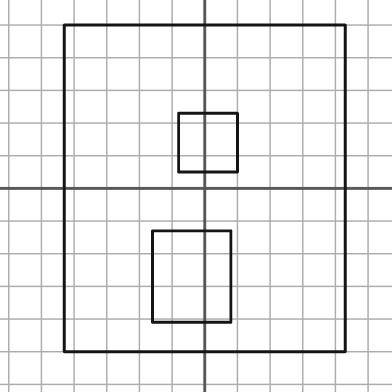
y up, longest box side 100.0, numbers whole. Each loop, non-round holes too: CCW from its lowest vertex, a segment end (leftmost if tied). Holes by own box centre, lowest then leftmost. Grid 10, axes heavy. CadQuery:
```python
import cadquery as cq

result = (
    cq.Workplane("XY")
    .moveTo(-43.0, -50.0)
    .lineTo(43.0, -50.0)
    .lineTo(43.0, 50.0)
    .lineTo(-43.0, 50.0)
    .close()
    .moveTo(-16.0, -41.0)
    .lineTo(8.0, -41.0)
    .lineTo(8.0, -13.0)
    .lineTo(-16.0, -13.0)
    .close()
    .moveTo(-8.0, 5.0)
    .lineTo(10.0, 5.0)
    .lineTo(10.0, 23.0)
    .lineTo(-8.0, 23.0)
    .close()
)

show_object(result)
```